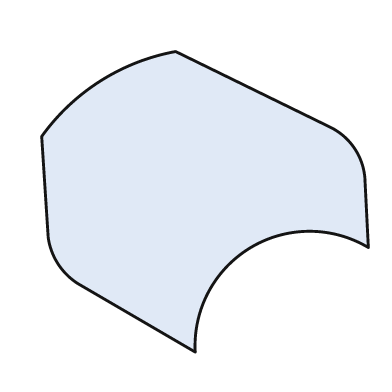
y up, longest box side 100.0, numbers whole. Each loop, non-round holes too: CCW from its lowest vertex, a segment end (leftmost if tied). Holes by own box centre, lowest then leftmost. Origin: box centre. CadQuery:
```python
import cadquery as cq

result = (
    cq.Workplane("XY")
    .moveTo(-3.0, -46.0)
    .threePointArc((14.0, -14.0), (50.0, -14.0))
    .lineTo(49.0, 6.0)
    .threePointArc((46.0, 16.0), (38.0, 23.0))
    .lineTo(-9.0, 46.0)
    .threePointArc((-32.0, 37.0), (-50.0, 20.0))
    .lineTo(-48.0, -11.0)
    .threePointArc((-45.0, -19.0), (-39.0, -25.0))
    .close()
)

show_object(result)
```